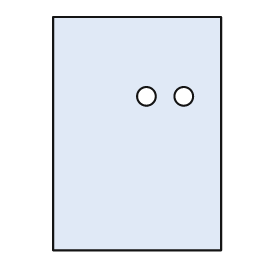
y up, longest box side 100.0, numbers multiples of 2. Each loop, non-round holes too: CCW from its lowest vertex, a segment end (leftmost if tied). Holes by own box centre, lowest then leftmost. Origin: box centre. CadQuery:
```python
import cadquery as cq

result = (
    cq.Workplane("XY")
    .moveTo(-36.0, -50.0)
    .lineTo(36.0, -50.0)
    .lineTo(36.0, 50.0)
    .lineTo(-36.0, 50.0)
    .close()
    .moveTo(4.0, 16.0)
    .circle(4.0)
    .moveTo(20.0, 16.0)
    .circle(4.0)
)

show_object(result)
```